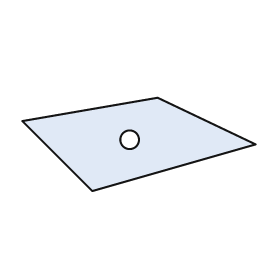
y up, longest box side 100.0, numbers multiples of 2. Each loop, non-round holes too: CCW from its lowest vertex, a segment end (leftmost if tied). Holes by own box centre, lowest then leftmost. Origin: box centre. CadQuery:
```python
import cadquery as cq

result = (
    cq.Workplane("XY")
    .moveTo(-20.0, -20.0)
    .lineTo(50.0, 0.0)
    .lineTo(8.0, 20.0)
    .lineTo(-50.0, 10.0)
    .close()
    .moveTo(-4.0, 2.0)
    .circle(4.0)
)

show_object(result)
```